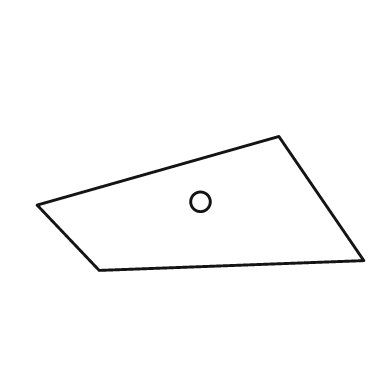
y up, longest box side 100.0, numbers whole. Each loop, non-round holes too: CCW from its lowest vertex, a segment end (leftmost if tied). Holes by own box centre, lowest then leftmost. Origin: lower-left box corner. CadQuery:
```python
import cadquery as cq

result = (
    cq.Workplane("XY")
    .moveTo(19.0, 0.0)
    .lineTo(100.0, 3.0)
    .lineTo(74.0, 41.0)
    .lineTo(0.0, 20.0)
    .close()
    .moveTo(50.0, 21.0)
    .circle(3.0)
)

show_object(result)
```